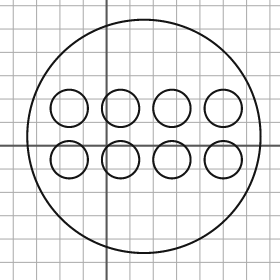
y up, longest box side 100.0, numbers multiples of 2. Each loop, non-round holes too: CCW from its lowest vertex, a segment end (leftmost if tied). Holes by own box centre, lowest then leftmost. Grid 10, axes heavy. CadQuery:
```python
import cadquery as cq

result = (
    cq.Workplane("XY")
    .moveTo(16.0, 4.0)
    .circle(50.0)
    .moveTo(-16.0, -6.0)
    .circle(8.0)
    .moveTo(6.0, -6.0)
    .circle(8.0)
    .moveTo(28.0, -6.0)
    .circle(8.0)
    .moveTo(50.0, -6.0)
    .circle(8.0)
    .moveTo(-16.0, 16.0)
    .circle(8.0)
    .moveTo(6.0, 16.0)
    .circle(8.0)
    .moveTo(28.0, 16.0)
    .circle(8.0)
    .moveTo(50.0, 16.0)
    .circle(8.0)
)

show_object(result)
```